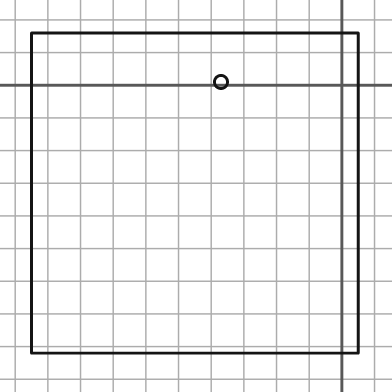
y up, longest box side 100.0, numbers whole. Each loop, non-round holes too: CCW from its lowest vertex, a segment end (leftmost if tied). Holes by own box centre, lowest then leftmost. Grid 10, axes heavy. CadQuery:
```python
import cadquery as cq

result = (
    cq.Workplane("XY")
    .moveTo(-95.0, -82.0)
    .lineTo(5.0, -82.0)
    .lineTo(5.0, 16.0)
    .lineTo(-95.0, 16.0)
    .close()
    .moveTo(-37.0, 1.0)
    .circle(2.0)
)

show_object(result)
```